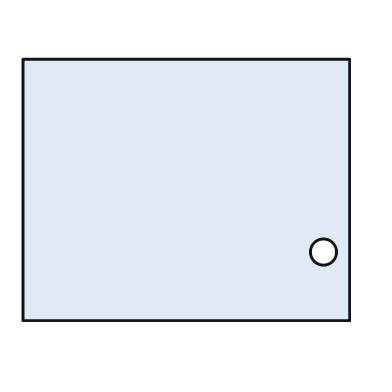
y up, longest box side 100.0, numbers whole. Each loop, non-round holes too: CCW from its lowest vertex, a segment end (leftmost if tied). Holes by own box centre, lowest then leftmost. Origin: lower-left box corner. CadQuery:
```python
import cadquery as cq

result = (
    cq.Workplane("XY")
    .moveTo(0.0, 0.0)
    .lineTo(100.0, 0.0)
    .lineTo(100.0, 80.0)
    .lineTo(0.0, 80.0)
    .close()
    .moveTo(92.0, 21.0)
    .circle(4.0)
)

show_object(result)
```